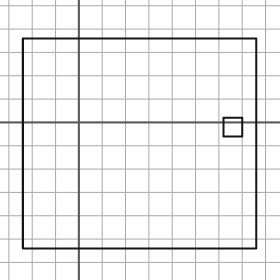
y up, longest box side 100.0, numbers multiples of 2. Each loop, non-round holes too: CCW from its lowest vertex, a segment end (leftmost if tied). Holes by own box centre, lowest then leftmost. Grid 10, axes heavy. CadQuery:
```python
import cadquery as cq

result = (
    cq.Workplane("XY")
    .moveTo(-24.0, -54.0)
    .lineTo(76.0, -54.0)
    .lineTo(76.0, 36.0)
    .lineTo(-24.0, 36.0)
    .close()
    .moveTo(62.0, -6.0)
    .lineTo(70.0, -6.0)
    .lineTo(70.0, 2.0)
    .lineTo(62.0, 2.0)
    .close()
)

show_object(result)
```